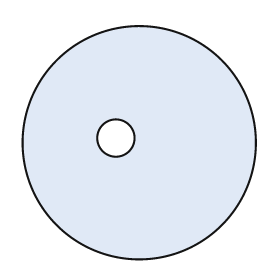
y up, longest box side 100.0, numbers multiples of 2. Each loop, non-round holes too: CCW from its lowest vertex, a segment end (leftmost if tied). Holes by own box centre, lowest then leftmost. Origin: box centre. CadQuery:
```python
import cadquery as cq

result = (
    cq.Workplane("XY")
    .moveTo(0.0, 0.0)
    .circle(50.0)
    .moveTo(-10.0, 2.0)
    .circle(8.0)
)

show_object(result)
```